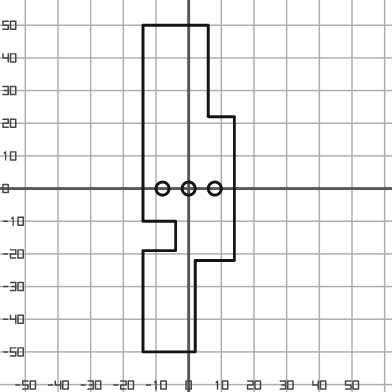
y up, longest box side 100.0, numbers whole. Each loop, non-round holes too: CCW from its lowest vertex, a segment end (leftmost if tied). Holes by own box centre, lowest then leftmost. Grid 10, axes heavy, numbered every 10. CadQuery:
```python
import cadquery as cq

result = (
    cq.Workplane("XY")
    .moveTo(-14.0, -50.0)
    .lineTo(2.0, -50.0)
    .lineTo(2.0, -22.0)
    .lineTo(14.0, -22.0)
    .lineTo(14.0, 22.0)
    .lineTo(6.0, 22.0)
    .lineTo(6.0, 50.0)
    .lineTo(-14.0, 50.0)
    .lineTo(-14.0, -10.0)
    .lineTo(-4.0, -10.0)
    .lineTo(-4.0, -19.0)
    .lineTo(-14.0, -19.0)
    .close()
    .moveTo(-8.0, 0.0)
    .circle(2.0)
    .moveTo(0.0, 0.0)
    .circle(2.0)
    .moveTo(8.0, 0.0)
    .circle(2.0)
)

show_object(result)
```